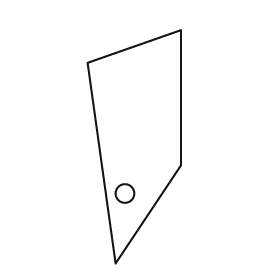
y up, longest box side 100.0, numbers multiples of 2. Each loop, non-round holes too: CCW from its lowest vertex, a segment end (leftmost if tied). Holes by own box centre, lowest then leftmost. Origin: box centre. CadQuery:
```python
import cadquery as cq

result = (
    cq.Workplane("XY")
    .moveTo(-8.0, -50.0)
    .lineTo(20.0, -8.0)
    .lineTo(20.0, 50.0)
    .lineTo(-20.0, 36.0)
    .close()
    .moveTo(-4.0, -20.0)
    .circle(4.0)
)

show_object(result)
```